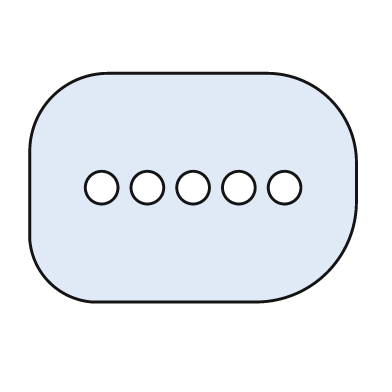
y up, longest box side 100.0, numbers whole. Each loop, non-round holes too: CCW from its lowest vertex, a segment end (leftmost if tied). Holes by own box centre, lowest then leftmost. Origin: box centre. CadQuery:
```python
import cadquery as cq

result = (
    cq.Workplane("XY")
    .moveTo(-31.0, -35.0)
    .lineTo(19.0, -35.0)
    .threePointArc((41.0, -26.0), (50.0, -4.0))
    .lineTo(50.0, 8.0)
    .threePointArc((42.0, 27.0), (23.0, 35.0))
    .lineTo(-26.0, 35.0)
    .threePointArc((-43.0, 28.0), (-50.0, 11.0))
    .lineTo(-50.0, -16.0)
    .threePointArc((-44.0, -29.0), (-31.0, -35.0))
    .close()
    .moveTo(-28.0, 0.0)
    .circle(5.0)
    .moveTo(-14.0, 0.0)
    .circle(5.0)
    .moveTo(0.0, 0.0)
    .circle(5.0)
    .moveTo(14.0, 0.0)
    .circle(5.0)
    .moveTo(28.0, 0.0)
    .circle(5.0)
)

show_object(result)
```